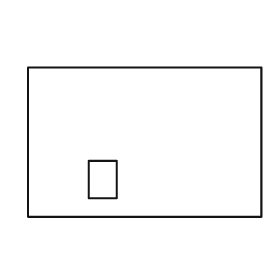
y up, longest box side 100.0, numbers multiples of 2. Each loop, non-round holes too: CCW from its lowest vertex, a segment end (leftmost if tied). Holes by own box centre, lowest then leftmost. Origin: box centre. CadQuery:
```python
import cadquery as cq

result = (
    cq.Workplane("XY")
    .moveTo(-50.0, -32.0)
    .lineTo(50.0, -32.0)
    .lineTo(50.0, 32.0)
    .lineTo(-50.0, 32.0)
    .close()
    .moveTo(-24.0, -24.0)
    .lineTo(-12.0, -24.0)
    .lineTo(-12.0, -8.0)
    .lineTo(-24.0, -8.0)
    .close()
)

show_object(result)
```